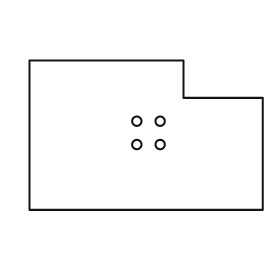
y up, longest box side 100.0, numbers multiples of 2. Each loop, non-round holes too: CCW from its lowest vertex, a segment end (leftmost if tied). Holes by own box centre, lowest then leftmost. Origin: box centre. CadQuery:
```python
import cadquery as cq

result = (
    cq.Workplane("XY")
    .moveTo(-50.0, -32.0)
    .lineTo(50.0, -32.0)
    .lineTo(50.0, 16.0)
    .lineTo(16.0, 16.0)
    .lineTo(16.0, 32.0)
    .lineTo(-50.0, 32.0)
    .close()
    .moveTo(-4.0, -4.0)
    .circle(2.0)
    .moveTo(6.0, -4.0)
    .circle(2.0)
    .moveTo(-4.0, 6.0)
    .circle(2.0)
    .moveTo(6.0, 6.0)
    .circle(2.0)
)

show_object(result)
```